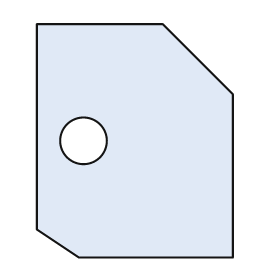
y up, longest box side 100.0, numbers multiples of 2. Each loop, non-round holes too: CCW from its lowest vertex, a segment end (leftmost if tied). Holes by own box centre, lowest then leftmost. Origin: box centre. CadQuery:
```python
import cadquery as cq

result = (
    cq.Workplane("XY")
    .moveTo(-24.0, -50.0)
    .lineTo(42.0, -50.0)
    .lineTo(42.0, 20.0)
    .lineTo(12.0, 50.0)
    .lineTo(-42.0, 50.0)
    .lineTo(-42.0, -38.0)
    .close()
    .moveTo(-22.0, 0.0)
    .circle(10.0)
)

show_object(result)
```